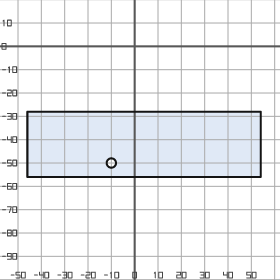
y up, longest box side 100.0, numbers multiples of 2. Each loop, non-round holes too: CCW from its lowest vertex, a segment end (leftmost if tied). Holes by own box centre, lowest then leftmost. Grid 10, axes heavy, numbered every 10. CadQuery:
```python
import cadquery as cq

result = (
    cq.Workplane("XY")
    .moveTo(-46.0, -56.0)
    .lineTo(54.0, -56.0)
    .lineTo(54.0, -28.0)
    .lineTo(-46.0, -28.0)
    .close()
    .moveTo(-10.0, -50.0)
    .circle(2.0)
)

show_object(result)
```